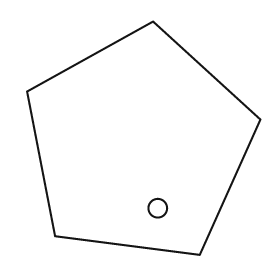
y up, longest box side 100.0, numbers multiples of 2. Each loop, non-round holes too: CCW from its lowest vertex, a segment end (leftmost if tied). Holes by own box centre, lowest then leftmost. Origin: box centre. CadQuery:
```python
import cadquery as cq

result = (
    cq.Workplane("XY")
    .moveTo(24.0, -50.0)
    .lineTo(50.0, 8.0)
    .lineTo(4.0, 50.0)
    .lineTo(-50.0, 20.0)
    .lineTo(-38.0, -42.0)
    .close()
    .moveTo(6.0, -30.0)
    .circle(4.0)
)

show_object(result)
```